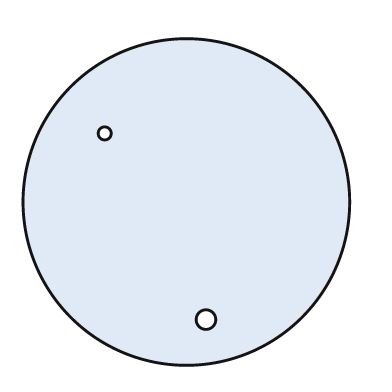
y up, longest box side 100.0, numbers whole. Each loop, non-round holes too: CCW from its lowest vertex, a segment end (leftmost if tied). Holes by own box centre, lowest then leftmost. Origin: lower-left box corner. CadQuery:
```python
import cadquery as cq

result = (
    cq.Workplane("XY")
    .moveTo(50.0, 50.0)
    .circle(50.0)
    .moveTo(56.0, 14.0)
    .circle(3.0)
    .moveTo(25.0, 71.0)
    .circle(2.0)
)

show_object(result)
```